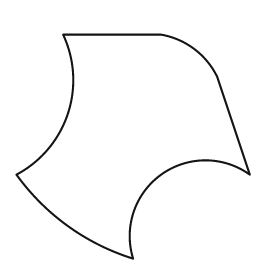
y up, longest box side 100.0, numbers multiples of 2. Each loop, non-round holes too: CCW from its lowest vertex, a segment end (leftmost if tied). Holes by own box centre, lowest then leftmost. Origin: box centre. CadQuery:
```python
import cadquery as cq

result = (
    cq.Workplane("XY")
    .moveTo(0.0, -48.0)
    .threePointArc((12.0, -12.0), (50.0, -12.0))
    .lineTo(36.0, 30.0)
    .threePointArc((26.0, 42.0), (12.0, 48.0))
    .lineTo(-30.0, 48.0)
    .threePointArc((-28.0, 14.0), (-50.0, -12.0))
    .threePointArc((-28.0, -34.0), (0.0, -48.0))
    .close()
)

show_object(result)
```